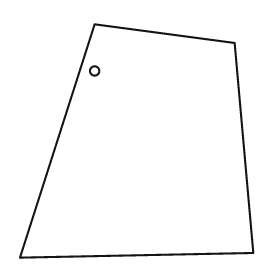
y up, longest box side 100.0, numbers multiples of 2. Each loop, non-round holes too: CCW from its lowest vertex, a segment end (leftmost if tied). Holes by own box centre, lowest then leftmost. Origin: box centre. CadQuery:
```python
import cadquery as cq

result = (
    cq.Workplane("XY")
    .moveTo(-50.0, -50.0)
    .lineTo(50.0, -48.0)
    .lineTo(42.0, 42.0)
    .lineTo(-18.0, 50.0)
    .close()
    .moveTo(-18.0, 30.0)
    .circle(2.0)
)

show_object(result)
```